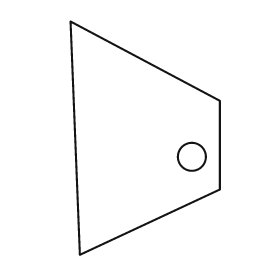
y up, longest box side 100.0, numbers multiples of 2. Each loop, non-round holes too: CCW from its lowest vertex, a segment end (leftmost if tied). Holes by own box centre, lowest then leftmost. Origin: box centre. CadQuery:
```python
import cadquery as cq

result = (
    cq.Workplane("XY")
    .moveTo(-28.0, -50.0)
    .lineTo(32.0, -22.0)
    .lineTo(32.0, 16.0)
    .lineTo(-32.0, 50.0)
    .close()
    .moveTo(20.0, -8.0)
    .circle(6.0)
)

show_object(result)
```